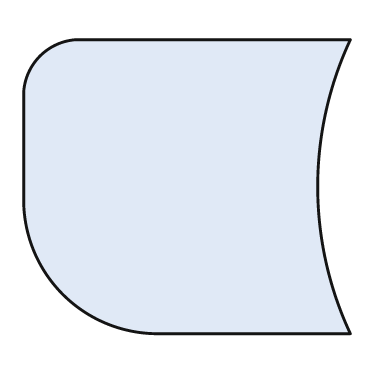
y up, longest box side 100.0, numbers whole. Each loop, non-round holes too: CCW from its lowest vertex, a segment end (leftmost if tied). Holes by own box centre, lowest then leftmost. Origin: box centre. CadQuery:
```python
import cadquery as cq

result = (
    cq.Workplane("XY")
    .moveTo(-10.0, -45.0)
    .lineTo(50.0, -45.0)
    .threePointArc((40.0, 0.0), (50.0, 45.0))
    .lineTo(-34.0, 45.0)
    .threePointArc((-45.0, 40.0), (-50.0, 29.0))
    .lineTo(-50.0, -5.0)
    .threePointArc((-38.0, -33.0), (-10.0, -45.0))
    .close()
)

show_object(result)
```